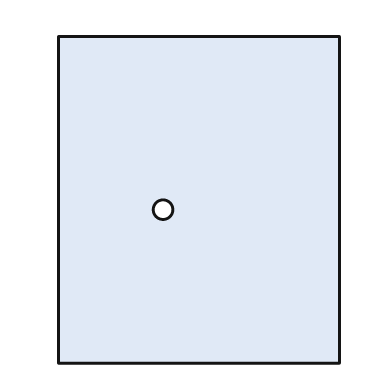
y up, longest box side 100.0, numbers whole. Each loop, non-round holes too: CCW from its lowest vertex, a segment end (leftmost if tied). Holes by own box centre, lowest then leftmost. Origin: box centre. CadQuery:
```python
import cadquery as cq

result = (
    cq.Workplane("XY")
    .moveTo(-43.0, -50.0)
    .lineTo(43.0, -50.0)
    .lineTo(43.0, 50.0)
    .lineTo(-43.0, 50.0)
    .close()
    .moveTo(-11.0, -3.0)
    .circle(3.0)
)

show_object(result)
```